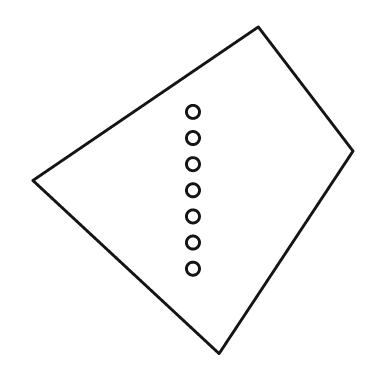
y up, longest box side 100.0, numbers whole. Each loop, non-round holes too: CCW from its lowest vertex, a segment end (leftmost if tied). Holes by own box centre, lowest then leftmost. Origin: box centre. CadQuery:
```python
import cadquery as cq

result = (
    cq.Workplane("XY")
    .moveTo(8.0, -50.0)
    .lineTo(49.0, 12.0)
    .lineTo(20.0, 50.0)
    .lineTo(-49.0, 3.0)
    .close()
    .moveTo(0.0, -24.0)
    .circle(2.0)
    .moveTo(0.0, -16.0)
    .circle(2.0)
    .moveTo(0.0, -8.0)
    .circle(2.0)
    .moveTo(0.0, 0.0)
    .circle(2.0)
    .moveTo(0.0, 8.0)
    .circle(2.0)
    .moveTo(0.0, 16.0)
    .circle(2.0)
    .moveTo(0.0, 24.0)
    .circle(2.0)
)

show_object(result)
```